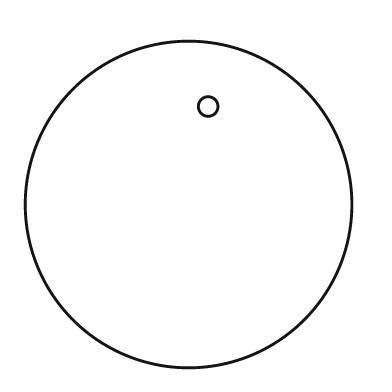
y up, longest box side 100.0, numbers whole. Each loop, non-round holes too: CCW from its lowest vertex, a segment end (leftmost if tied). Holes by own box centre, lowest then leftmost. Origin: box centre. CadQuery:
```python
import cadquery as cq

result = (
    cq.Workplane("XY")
    .moveTo(0.0, 0.0)
    .circle(50.0)
    .moveTo(6.0, 30.0)
    .circle(3.0)
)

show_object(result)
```